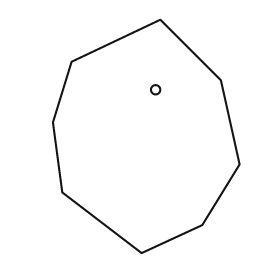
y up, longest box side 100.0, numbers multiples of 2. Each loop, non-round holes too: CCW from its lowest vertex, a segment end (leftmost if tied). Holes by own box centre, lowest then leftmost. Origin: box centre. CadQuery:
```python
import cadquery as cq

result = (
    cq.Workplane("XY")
    .moveTo(-2.0, -50.0)
    .lineTo(24.0, -38.0)
    .lineTo(40.0, -12.0)
    .lineTo(32.0, 24.0)
    .lineTo(6.0, 50.0)
    .lineTo(-32.0, 32.0)
    .lineTo(-40.0, 6.0)
    .lineTo(-36.0, -24.0)
    .close()
    .moveTo(4.0, 20.0)
    .circle(2.0)
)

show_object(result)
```